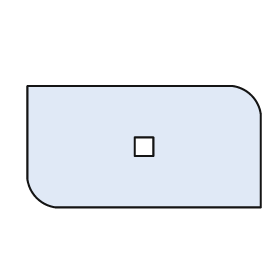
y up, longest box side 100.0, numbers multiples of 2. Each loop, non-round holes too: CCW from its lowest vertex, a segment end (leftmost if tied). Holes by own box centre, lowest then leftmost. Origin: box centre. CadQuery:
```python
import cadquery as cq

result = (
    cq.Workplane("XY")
    .moveTo(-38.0, -26.0)
    .lineTo(50.0, -26.0)
    .lineTo(50.0, 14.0)
    .threePointArc((46.0, 22.0), (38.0, 26.0))
    .lineTo(-50.0, 26.0)
    .lineTo(-50.0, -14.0)
    .threePointArc((-46.0, -22.0), (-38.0, -26.0))
    .close()
    .moveTo(-4.0, -4.0)
    .lineTo(4.0, -4.0)
    .lineTo(4.0, 4.0)
    .lineTo(-4.0, 4.0)
    .close()
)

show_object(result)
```